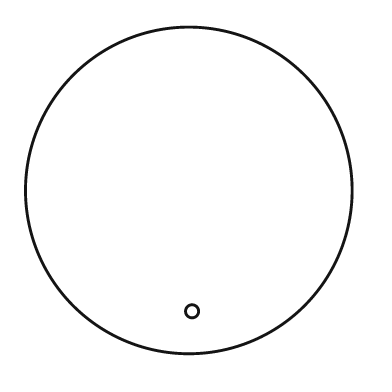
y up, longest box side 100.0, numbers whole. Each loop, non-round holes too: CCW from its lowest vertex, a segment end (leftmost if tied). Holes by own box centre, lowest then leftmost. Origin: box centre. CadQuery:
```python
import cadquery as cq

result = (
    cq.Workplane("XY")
    .moveTo(0.0, 0.0)
    .circle(50.0)
    .moveTo(1.0, -37.0)
    .circle(2.0)
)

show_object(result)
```